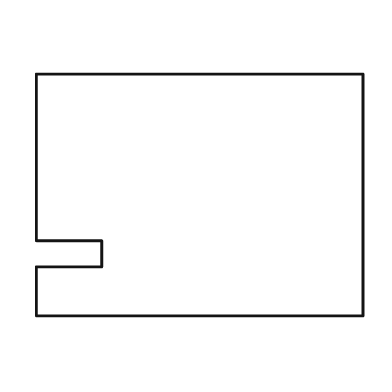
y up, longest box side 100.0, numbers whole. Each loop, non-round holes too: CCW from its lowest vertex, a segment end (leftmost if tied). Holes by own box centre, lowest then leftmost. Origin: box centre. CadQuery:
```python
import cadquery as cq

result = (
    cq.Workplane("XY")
    .moveTo(-50.0, -37.0)
    .lineTo(50.0, -37.0)
    .lineTo(50.0, 37.0)
    .lineTo(-50.0, 37.0)
    .lineTo(-50.0, -14.0)
    .lineTo(-30.0, -14.0)
    .lineTo(-30.0, -22.0)
    .lineTo(-50.0, -22.0)
    .close()
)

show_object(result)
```